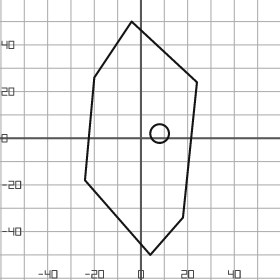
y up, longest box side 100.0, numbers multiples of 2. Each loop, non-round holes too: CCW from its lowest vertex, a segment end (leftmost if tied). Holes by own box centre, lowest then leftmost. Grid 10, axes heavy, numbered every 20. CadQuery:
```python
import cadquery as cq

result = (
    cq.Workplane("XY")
    .moveTo(4.0, -50.0)
    .lineTo(18.0, -34.0)
    .lineTo(24.0, 24.0)
    .lineTo(-4.0, 50.0)
    .lineTo(-20.0, 26.0)
    .lineTo(-24.0, -18.0)
    .close()
    .moveTo(8.0, 2.0)
    .circle(4.0)
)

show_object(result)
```